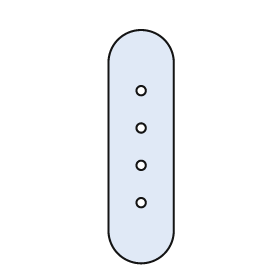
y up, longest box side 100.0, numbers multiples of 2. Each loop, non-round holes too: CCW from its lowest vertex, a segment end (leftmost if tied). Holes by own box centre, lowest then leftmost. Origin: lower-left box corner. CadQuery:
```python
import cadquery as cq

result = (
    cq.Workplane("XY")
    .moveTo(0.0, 14.0)
    .threePointArc((14.0, 0.0), (28.0, 14.0))
    .lineTo(28.0, 86.0)
    .threePointArc((14.0, 100.0), (0.0, 86.0))
    .close()
    .moveTo(14.0, 26.0)
    .circle(2.0)
    .moveTo(14.0, 42.0)
    .circle(2.0)
    .moveTo(14.0, 58.0)
    .circle(2.0)
    .moveTo(14.0, 74.0)
    .circle(2.0)
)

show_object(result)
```